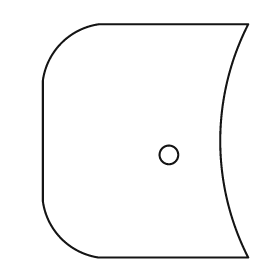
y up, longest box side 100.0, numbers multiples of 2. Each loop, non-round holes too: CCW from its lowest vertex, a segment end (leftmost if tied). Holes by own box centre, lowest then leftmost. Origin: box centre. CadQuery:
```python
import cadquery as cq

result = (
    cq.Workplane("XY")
    .moveTo(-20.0, -50.0)
    .lineTo(44.0, -50.0)
    .threePointArc((32.0, 0.0), (44.0, 50.0))
    .lineTo(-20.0, 50.0)
    .threePointArc((-36.0, 42.0), (-44.0, 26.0))
    .lineTo(-44.0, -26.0)
    .threePointArc((-36.0, -42.0), (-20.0, -50.0))
    .close()
    .moveTo(10.0, -6.0)
    .circle(4.0)
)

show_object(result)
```